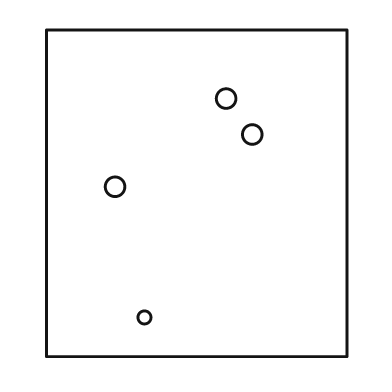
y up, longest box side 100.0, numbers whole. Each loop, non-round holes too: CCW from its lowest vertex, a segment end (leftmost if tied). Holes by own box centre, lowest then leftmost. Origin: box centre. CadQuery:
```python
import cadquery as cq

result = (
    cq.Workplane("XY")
    .moveTo(-46.0, -50.0)
    .lineTo(46.0, -50.0)
    .lineTo(46.0, 50.0)
    .lineTo(-46.0, 50.0)
    .close()
    .moveTo(-16.0, -38.0)
    .circle(2.0)
    .moveTo(-25.0, 2.0)
    .circle(3.0)
    .moveTo(17.0, 18.0)
    .circle(3.0)
    .moveTo(9.0, 29.0)
    .circle(3.0)
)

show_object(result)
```